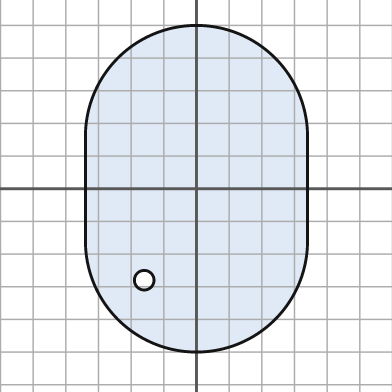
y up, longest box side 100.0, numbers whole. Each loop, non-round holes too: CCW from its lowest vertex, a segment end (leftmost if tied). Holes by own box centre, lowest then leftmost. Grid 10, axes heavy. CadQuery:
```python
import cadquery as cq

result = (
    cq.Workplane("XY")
    .moveTo(-34.0, -16.0)
    .threePointArc((0.0, -50.0), (34.0, -16.0))
    .lineTo(34.0, 16.0)
    .threePointArc((0.0, 50.0), (-34.0, 16.0))
    .close()
    .moveTo(-16.0, -28.0)
    .circle(3.0)
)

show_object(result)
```